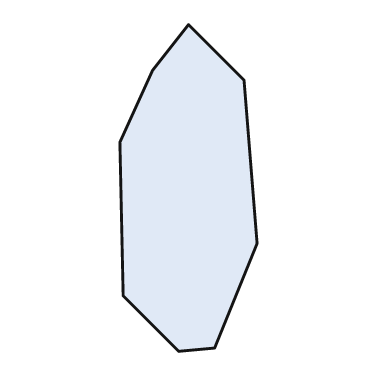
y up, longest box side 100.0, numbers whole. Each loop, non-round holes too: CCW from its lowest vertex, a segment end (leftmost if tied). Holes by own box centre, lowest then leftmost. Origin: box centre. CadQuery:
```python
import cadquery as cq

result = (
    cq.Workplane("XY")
    .moveTo(-3.0, -50.0)
    .lineTo(8.0, -49.0)
    .lineTo(21.0, -17.0)
    .lineTo(17.0, 33.0)
    .lineTo(0.0, 50.0)
    .lineTo(-11.0, 36.0)
    .lineTo(-21.0, 14.0)
    .lineTo(-20.0, -33.0)
    .close()
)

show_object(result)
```